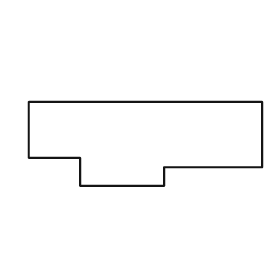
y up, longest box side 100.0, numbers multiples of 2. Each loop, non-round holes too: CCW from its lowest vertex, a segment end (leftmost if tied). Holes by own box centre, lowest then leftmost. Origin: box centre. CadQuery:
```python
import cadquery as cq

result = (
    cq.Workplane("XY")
    .moveTo(-28.0, -18.0)
    .lineTo(8.0, -18.0)
    .lineTo(8.0, -10.0)
    .lineTo(50.0, -10.0)
    .lineTo(50.0, 18.0)
    .lineTo(-50.0, 18.0)
    .lineTo(-50.0, -6.0)
    .lineTo(-28.0, -6.0)
    .close()
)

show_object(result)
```